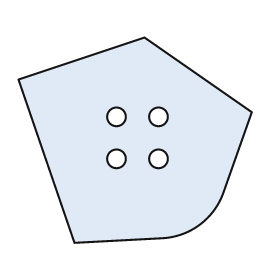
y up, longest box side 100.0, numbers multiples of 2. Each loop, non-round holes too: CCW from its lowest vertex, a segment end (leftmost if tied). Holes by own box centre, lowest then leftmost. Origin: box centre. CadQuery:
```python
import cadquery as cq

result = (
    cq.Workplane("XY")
    .moveTo(-26.0, -44.0)
    .lineTo(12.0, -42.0)
    .threePointArc((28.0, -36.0), (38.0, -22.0))
    .lineTo(50.0, 12.0)
    .lineTo(4.0, 44.0)
    .lineTo(-50.0, 26.0)
    .close()
    .moveTo(-8.0, -8.0)
    .circle(4.0)
    .moveTo(10.0, -8.0)
    .circle(4.0)
    .moveTo(-8.0, 10.0)
    .circle(4.0)
    .moveTo(10.0, 10.0)
    .circle(4.0)
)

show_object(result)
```